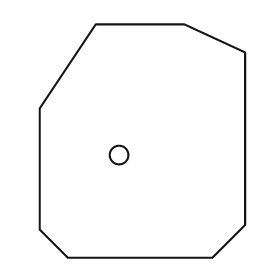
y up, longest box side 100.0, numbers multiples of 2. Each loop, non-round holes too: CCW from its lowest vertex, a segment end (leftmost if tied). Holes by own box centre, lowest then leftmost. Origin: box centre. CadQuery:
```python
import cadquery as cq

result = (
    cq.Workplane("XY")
    .moveTo(-32.0, -50.0)
    .lineTo(30.0, -50.0)
    .lineTo(44.0, -36.0)
    .lineTo(44.0, 38.0)
    .lineTo(18.0, 50.0)
    .lineTo(-20.0, 50.0)
    .lineTo(-44.0, 14.0)
    .lineTo(-44.0, -38.0)
    .close()
    .moveTo(-10.0, -6.0)
    .circle(4.0)
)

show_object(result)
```